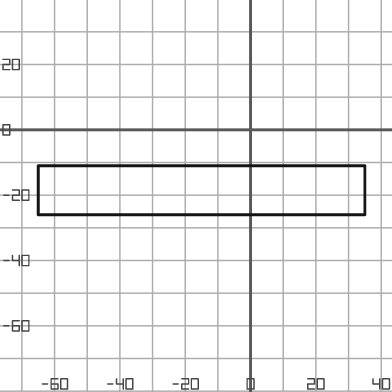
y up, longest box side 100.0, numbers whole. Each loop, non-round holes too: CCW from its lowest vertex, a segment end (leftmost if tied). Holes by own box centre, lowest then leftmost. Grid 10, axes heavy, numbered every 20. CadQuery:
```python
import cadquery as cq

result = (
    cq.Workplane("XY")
    .moveTo(-65.0, -26.0)
    .lineTo(35.0, -26.0)
    .lineTo(35.0, -11.0)
    .lineTo(-65.0, -11.0)
    .close()
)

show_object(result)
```